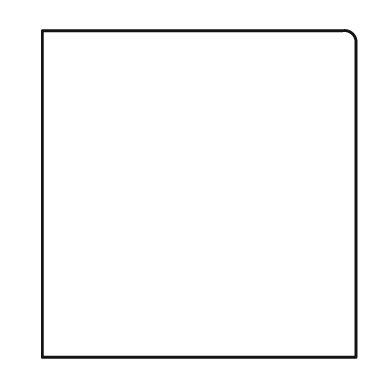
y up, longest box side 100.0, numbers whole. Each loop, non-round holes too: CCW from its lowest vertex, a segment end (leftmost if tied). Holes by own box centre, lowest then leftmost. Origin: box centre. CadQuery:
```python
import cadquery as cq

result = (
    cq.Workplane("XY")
    .moveTo(-48.0, -50.0)
    .lineTo(48.0, -50.0)
    .lineTo(48.0, 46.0)
    .threePointArc((47.0, 49.0), (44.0, 50.0))
    .lineTo(-48.0, 50.0)
    .close()
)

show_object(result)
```